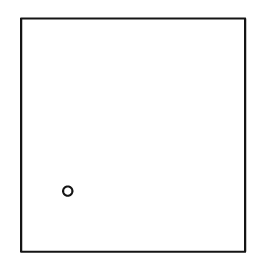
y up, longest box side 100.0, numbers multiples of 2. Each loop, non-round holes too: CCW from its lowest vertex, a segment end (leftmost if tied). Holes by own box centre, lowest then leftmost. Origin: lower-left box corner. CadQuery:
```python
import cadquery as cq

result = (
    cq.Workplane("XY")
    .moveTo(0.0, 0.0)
    .lineTo(96.0, 0.0)
    .lineTo(96.0, 100.0)
    .lineTo(0.0, 100.0)
    .close()
    .moveTo(20.0, 26.0)
    .circle(2.0)
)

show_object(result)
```